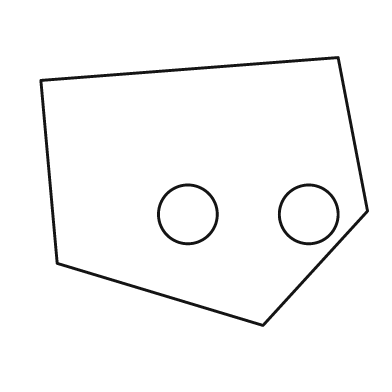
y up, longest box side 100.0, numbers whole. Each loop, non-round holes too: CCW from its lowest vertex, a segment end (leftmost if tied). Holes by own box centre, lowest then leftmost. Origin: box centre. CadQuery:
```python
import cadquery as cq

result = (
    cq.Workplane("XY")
    .moveTo(18.0, -41.0)
    .lineTo(50.0, -6.0)
    .lineTo(41.0, 41.0)
    .lineTo(-50.0, 34.0)
    .lineTo(-45.0, -22.0)
    .close()
    .moveTo(-5.0, -7.0)
    .circle(9.0)
    .moveTo(32.0, -7.0)
    .circle(9.0)
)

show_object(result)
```